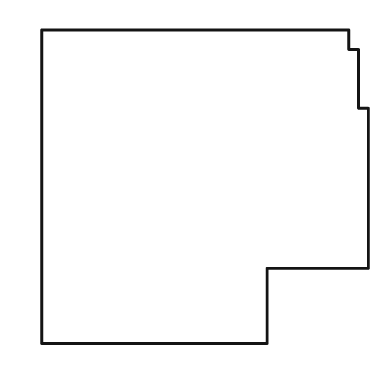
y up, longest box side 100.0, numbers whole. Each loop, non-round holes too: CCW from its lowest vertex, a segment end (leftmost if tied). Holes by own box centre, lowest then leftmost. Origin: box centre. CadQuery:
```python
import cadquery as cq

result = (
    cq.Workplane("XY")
    .moveTo(-50.0, -48.0)
    .lineTo(19.0, -48.0)
    .lineTo(19.0, -25.0)
    .lineTo(50.0, -25.0)
    .lineTo(50.0, 24.0)
    .lineTo(47.0, 24.0)
    .lineTo(47.0, 42.0)
    .lineTo(44.0, 42.0)
    .lineTo(44.0, 48.0)
    .lineTo(-50.0, 48.0)
    .close()
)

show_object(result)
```